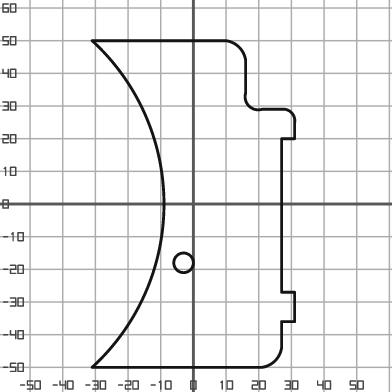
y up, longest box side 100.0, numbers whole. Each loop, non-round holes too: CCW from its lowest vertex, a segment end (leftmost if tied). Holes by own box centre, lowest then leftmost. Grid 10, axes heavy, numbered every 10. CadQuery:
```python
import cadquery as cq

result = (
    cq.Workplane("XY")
    .moveTo(-31.0, -50.0)
    .lineTo(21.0, -50.0)
    .threePointArc((25.0, -48.0), (27.0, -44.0))
    .lineTo(27.0, -36.0)
    .lineTo(31.0, -36.0)
    .lineTo(31.0, -27.0)
    .lineTo(27.0, -27.0)
    .lineTo(27.0, 20.0)
    .lineTo(31.0, 20.0)
    .lineTo(31.0, 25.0)
    .threePointArc((30.0, 28.0), (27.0, 29.0))
    .lineTo(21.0, 29.0)
    .threePointArc((17.0, 30.0), (16.0, 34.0))
    .lineTo(16.0, 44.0)
    .threePointArc((14.0, 48.0), (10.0, 50.0))
    .lineTo(-31.0, 50.0)
    .threePointArc((-9.0, 0.0), (-31.0, -50.0))
    .close()
    .moveTo(-3.0, -18.0)
    .circle(3.0)
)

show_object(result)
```